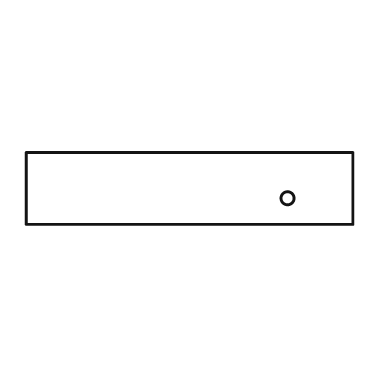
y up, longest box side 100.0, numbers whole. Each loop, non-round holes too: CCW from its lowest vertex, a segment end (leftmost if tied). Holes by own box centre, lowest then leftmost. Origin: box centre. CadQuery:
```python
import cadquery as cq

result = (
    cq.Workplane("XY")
    .moveTo(-50.0, -11.0)
    .lineTo(50.0, -11.0)
    .lineTo(50.0, 11.0)
    .lineTo(-50.0, 11.0)
    .close()
    .moveTo(30.0, -3.0)
    .circle(2.0)
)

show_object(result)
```